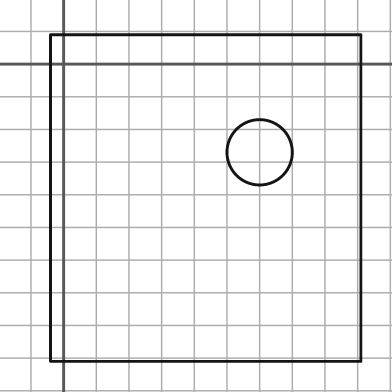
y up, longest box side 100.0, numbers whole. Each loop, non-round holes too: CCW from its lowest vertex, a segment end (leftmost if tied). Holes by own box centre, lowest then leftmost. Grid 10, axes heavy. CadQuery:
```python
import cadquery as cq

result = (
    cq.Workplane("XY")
    .moveTo(-4.0, -91.0)
    .lineTo(91.0, -91.0)
    .lineTo(91.0, 9.0)
    .lineTo(-4.0, 9.0)
    .close()
    .moveTo(60.0, -27.0)
    .circle(10.0)
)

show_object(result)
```